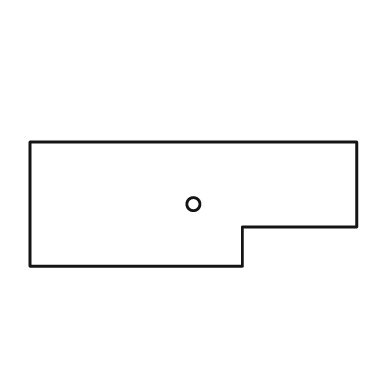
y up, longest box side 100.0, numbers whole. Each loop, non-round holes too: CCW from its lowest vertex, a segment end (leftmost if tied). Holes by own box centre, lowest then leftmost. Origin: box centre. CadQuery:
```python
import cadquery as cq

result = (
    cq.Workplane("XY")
    .moveTo(-50.0, -19.0)
    .lineTo(15.0, -19.0)
    .lineTo(15.0, -7.0)
    .lineTo(50.0, -7.0)
    .lineTo(50.0, 19.0)
    .lineTo(-50.0, 19.0)
    .close()
    .moveTo(0.0, 0.0)
    .circle(2.0)
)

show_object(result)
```